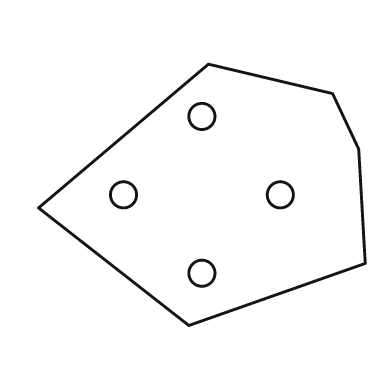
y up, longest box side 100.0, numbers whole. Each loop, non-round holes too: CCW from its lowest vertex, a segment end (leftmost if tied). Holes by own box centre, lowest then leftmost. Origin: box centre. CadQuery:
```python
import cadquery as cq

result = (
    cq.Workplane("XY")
    .moveTo(-4.0, -40.0)
    .lineTo(50.0, -21.0)
    .lineTo(48.0, 14.0)
    .lineTo(40.0, 31.0)
    .lineTo(2.0, 40.0)
    .lineTo(-50.0, -4.0)
    .close()
    .moveTo(0.0, -24.0)
    .circle(4.0)
    .moveTo(-24.0, 0.0)
    .circle(4.0)
    .moveTo(24.0, 0.0)
    .circle(4.0)
    .moveTo(0.0, 24.0)
    .circle(4.0)
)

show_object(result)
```